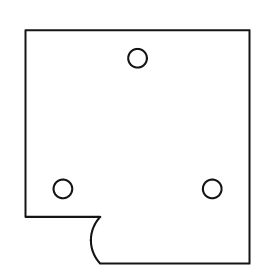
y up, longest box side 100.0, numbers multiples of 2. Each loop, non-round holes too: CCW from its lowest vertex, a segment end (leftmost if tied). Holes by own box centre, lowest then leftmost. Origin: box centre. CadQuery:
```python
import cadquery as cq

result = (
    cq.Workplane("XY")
    .moveTo(-16.0, -50.0)
    .lineTo(48.0, -50.0)
    .lineTo(48.0, 50.0)
    .lineTo(-48.0, 50.0)
    .lineTo(-48.0, -30.0)
    .lineTo(-16.0, -30.0)
    .threePointArc((-20.0, -40.0), (-16.0, -50.0))
    .close()
    .moveTo(-32.0, -18.0)
    .circle(4.0)
    .moveTo(32.0, -18.0)
    .circle(4.0)
    .moveTo(0.0, 38.0)
    .circle(4.0)
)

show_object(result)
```